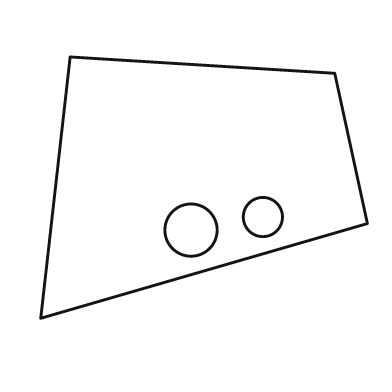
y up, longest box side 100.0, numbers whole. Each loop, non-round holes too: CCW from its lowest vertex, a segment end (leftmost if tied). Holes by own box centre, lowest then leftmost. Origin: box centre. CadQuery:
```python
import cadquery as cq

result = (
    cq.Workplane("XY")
    .moveTo(-50.0, -40.0)
    .lineTo(50.0, -11.0)
    .lineTo(40.0, 35.0)
    .lineTo(-41.0, 40.0)
    .close()
    .moveTo(-4.0, -13.0)
    .circle(8.0)
    .moveTo(18.0, -9.0)
    .circle(6.0)
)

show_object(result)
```